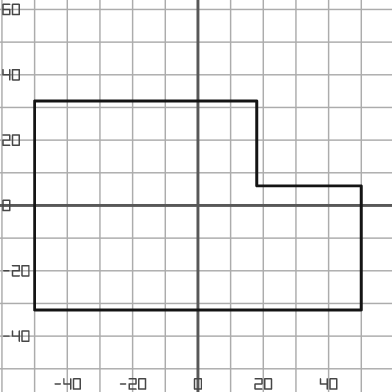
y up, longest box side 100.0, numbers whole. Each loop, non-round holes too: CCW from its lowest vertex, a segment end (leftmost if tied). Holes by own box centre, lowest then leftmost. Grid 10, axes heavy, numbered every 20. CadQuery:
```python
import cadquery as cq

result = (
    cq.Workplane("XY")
    .moveTo(-50.0, -32.0)
    .lineTo(50.0, -32.0)
    .lineTo(50.0, 6.0)
    .lineTo(18.0, 6.0)
    .lineTo(18.0, 32.0)
    .lineTo(-50.0, 32.0)
    .close()
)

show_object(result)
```